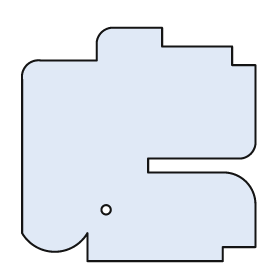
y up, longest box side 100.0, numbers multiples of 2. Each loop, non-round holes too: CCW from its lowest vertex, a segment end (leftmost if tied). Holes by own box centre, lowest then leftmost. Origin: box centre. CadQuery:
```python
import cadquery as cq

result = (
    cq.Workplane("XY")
    .moveTo(-22.0, -50.0)
    .lineTo(36.0, -50.0)
    .lineTo(36.0, -44.0)
    .lineTo(50.0, -44.0)
    .lineTo(50.0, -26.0)
    .threePointArc((46.0, -16.0), (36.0, -12.0))
    .lineTo(4.0, -12.0)
    .lineTo(4.0, -6.0)
    .lineTo(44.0, -6.0)
    .threePointArc((48.0, -4.0), (50.0, 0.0))
    .lineTo(50.0, 34.0)
    .lineTo(40.0, 34.0)
    .lineTo(40.0, 42.0)
    .lineTo(10.0, 42.0)
    .lineTo(10.0, 50.0)
    .lineTo(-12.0, 50.0)
    .threePointArc((-16.0, 48.0), (-18.0, 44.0))
    .lineTo(-18.0, 36.0)
    .lineTo(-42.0, 36.0)
    .threePointArc((-48.0, 34.0), (-50.0, 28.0))
    .lineTo(-50.0, -38.0)
    .threePointArc((-36.0, -46.0), (-22.0, -38.0))
    .close()
    .moveTo(-14.0, -28.0)
    .circle(2.0)
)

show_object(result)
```